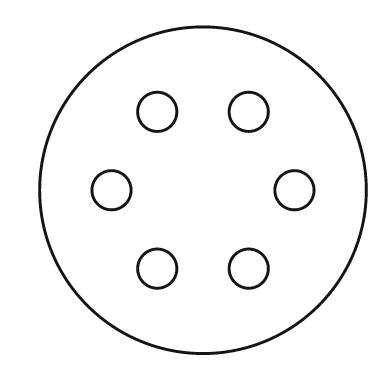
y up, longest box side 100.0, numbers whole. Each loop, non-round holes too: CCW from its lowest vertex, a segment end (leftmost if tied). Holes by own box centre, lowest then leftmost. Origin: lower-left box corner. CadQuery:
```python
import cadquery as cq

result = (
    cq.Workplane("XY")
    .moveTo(50.0, 50.0)
    .circle(50.0)
    .moveTo(36.0, 26.0)
    .circle(6.0)
    .moveTo(64.0, 26.0)
    .circle(6.0)
    .moveTo(22.0, 50.0)
    .circle(6.0)
    .moveTo(78.0, 50.0)
    .circle(6.0)
    .moveTo(36.0, 74.0)
    .circle(6.0)
    .moveTo(64.0, 74.0)
    .circle(6.0)
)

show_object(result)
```